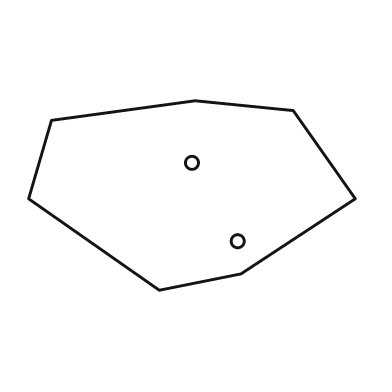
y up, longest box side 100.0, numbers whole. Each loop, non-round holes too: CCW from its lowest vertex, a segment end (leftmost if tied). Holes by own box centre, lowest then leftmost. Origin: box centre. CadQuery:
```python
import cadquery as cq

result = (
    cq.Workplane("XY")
    .moveTo(-10.0, -29.0)
    .lineTo(15.0, -24.0)
    .lineTo(50.0, -1.0)
    .lineTo(31.0, 26.0)
    .lineTo(1.0, 29.0)
    .lineTo(-43.0, 23.0)
    .lineTo(-50.0, -1.0)
    .close()
    .moveTo(14.0, -14.0)
    .circle(2.0)
    .moveTo(0.0, 10.0)
    .circle(2.0)
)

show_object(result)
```